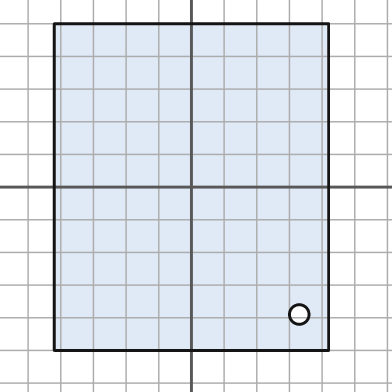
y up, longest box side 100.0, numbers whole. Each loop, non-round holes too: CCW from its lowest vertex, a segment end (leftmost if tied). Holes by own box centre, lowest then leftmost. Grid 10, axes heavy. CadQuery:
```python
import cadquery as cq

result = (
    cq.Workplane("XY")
    .moveTo(-42.0, -50.0)
    .lineTo(42.0, -50.0)
    .lineTo(42.0, 50.0)
    .lineTo(-42.0, 50.0)
    .close()
    .moveTo(33.0, -39.0)
    .circle(3.0)
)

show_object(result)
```